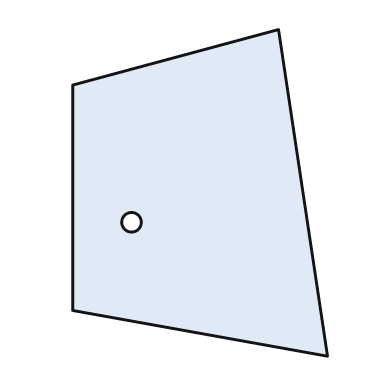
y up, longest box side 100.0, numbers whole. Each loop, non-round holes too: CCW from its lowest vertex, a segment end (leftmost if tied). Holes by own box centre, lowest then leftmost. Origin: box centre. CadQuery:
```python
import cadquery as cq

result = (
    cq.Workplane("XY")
    .moveTo(39.0, -50.0)
    .lineTo(24.0, 50.0)
    .lineTo(-39.0, 33.0)
    .lineTo(-39.0, -36.0)
    .close()
    .moveTo(-21.0, -9.0)
    .circle(3.0)
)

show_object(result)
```